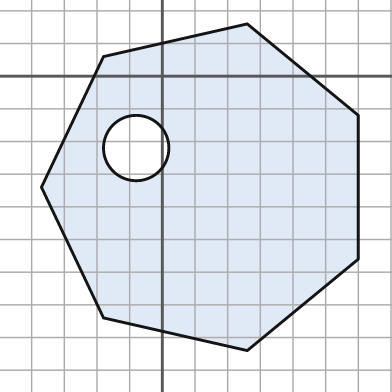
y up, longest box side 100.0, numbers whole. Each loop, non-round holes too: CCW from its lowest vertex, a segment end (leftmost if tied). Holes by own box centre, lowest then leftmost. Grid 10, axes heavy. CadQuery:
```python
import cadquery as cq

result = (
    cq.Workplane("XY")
    .moveTo(26.0, -84.0)
    .lineTo(60.0, -56.0)
    .lineTo(60.0, -12.0)
    .lineTo(26.0, 16.0)
    .lineTo(-18.0, 6.0)
    .lineTo(-37.0, -34.0)
    .lineTo(-18.0, -74.0)
    .close()
    .moveTo(-8.0, -22.0)
    .circle(10.0)
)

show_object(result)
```